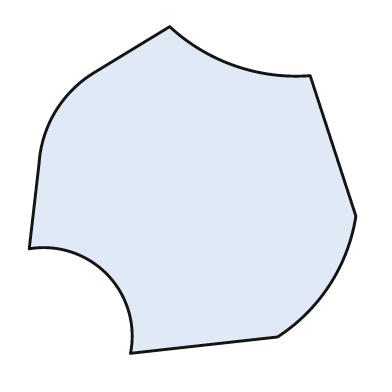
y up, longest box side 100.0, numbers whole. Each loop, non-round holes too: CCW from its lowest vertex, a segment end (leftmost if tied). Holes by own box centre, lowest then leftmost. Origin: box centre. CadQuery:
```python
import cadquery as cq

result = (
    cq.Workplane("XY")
    .moveTo(-19.0, -50.0)
    .lineTo(26.0, -45.0)
    .threePointArc((42.0, -29.0), (50.0, -8.0))
    .lineTo(36.0, 35.0)
    .threePointArc((13.0, 38.0), (-7.0, 50.0))
    .lineTo(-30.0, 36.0)
    .threePointArc((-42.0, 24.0), (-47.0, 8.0))
    .lineTo(-50.0, -18.0)
    .threePointArc((-26.0, -26.0), (-19.0, -50.0))
    .close()
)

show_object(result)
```